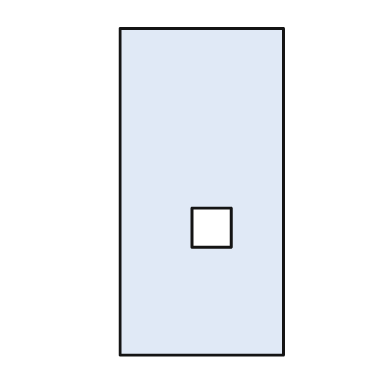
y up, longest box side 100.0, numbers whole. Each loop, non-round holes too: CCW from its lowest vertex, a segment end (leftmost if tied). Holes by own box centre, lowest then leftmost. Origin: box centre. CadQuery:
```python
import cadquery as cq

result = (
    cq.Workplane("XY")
    .moveTo(-25.0, -50.0)
    .lineTo(25.0, -50.0)
    .lineTo(25.0, 50.0)
    .lineTo(-25.0, 50.0)
    .close()
    .moveTo(-3.0, -17.0)
    .lineTo(9.0, -17.0)
    .lineTo(9.0, -5.0)
    .lineTo(-3.0, -5.0)
    .close()
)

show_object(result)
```